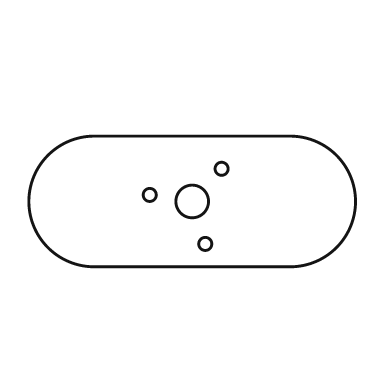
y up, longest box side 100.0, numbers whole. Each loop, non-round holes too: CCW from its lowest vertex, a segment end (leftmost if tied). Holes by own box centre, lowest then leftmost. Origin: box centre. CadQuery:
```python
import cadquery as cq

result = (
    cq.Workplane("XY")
    .moveTo(-30.0, -20.0)
    .lineTo(30.0, -20.0)
    .threePointArc((50.0, 0.0), (30.0, 20.0))
    .lineTo(-30.0, 20.0)
    .threePointArc((-50.0, 0.0), (-30.0, -20.0))
    .close()
    .moveTo(4.0, -13.0)
    .circle(2.0)
    .moveTo(0.0, 0.0)
    .circle(5.0)
    .moveTo(-13.0, 2.0)
    .circle(2.0)
    .moveTo(9.0, 10.0)
    .circle(2.0)
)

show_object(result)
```